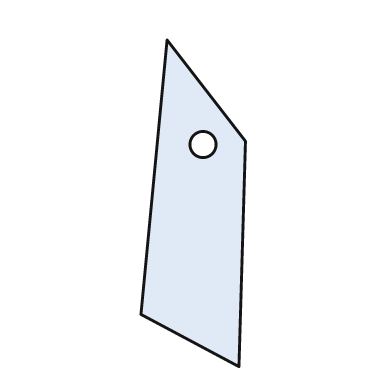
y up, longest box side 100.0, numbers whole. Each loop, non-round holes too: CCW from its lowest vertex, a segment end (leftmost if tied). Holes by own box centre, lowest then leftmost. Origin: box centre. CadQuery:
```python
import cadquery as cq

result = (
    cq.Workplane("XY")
    .moveTo(14.0, -50.0)
    .lineTo(16.0, 19.0)
    .lineTo(-8.0, 50.0)
    .lineTo(-16.0, -34.0)
    .close()
    .moveTo(3.0, 18.0)
    .circle(4.0)
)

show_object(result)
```